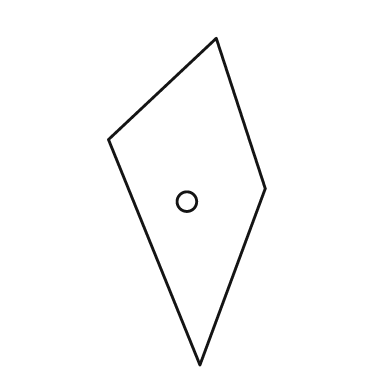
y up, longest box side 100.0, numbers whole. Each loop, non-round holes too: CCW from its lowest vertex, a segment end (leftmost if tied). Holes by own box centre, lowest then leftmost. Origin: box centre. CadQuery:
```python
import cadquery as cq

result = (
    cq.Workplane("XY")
    .moveTo(4.0, -50.0)
    .lineTo(24.0, 4.0)
    .lineTo(9.0, 50.0)
    .lineTo(-24.0, 19.0)
    .close()
    .moveTo(0.0, 0.0)
    .circle(3.0)
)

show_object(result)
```